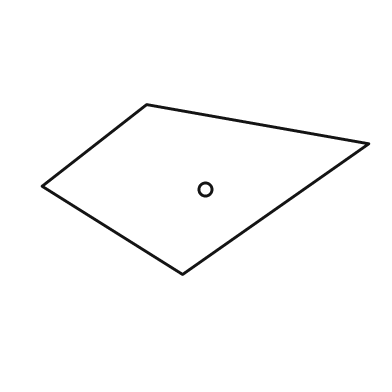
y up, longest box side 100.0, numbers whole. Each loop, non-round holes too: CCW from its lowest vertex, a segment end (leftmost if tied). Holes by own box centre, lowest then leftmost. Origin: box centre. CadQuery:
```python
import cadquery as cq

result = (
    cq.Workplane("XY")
    .moveTo(-7.0, -26.0)
    .lineTo(50.0, 14.0)
    .lineTo(-18.0, 26.0)
    .lineTo(-50.0, 1.0)
    .close()
    .moveTo(0.0, 0.0)
    .circle(2.0)
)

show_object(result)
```